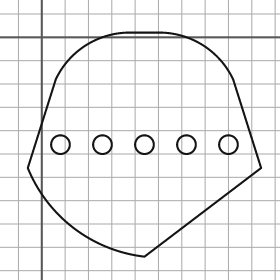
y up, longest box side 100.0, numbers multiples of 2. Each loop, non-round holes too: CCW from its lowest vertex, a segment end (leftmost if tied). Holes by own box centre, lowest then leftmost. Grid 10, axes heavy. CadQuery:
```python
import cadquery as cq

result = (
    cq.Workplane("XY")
    .moveTo(44.0, -94.0)
    .lineTo(94.0, -56.0)
    .lineTo(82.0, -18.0)
    .threePointArc((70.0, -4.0), (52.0, 2.0))
    .lineTo(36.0, 2.0)
    .threePointArc((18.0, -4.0), (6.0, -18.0))
    .lineTo(-6.0, -56.0)
    .threePointArc((14.0, -82.0), (44.0, -94.0))
    .close()
    .moveTo(8.0, -46.0)
    .circle(4.0)
    .moveTo(26.0, -46.0)
    .circle(4.0)
    .moveTo(44.0, -46.0)
    .circle(4.0)
    .moveTo(62.0, -46.0)
    .circle(4.0)
    .moveTo(80.0, -46.0)
    .circle(4.0)
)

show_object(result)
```